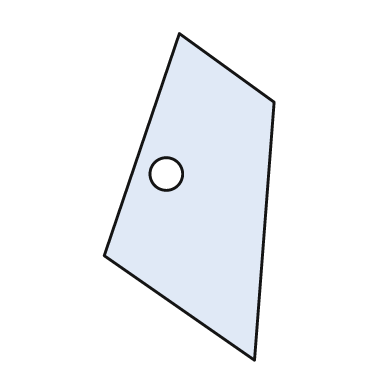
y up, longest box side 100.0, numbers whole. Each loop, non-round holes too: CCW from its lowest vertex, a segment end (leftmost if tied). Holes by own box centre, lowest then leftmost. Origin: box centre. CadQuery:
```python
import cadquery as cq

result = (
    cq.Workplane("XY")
    .moveTo(20.0, -50.0)
    .lineTo(26.0, 29.0)
    .lineTo(-3.0, 50.0)
    .lineTo(-26.0, -18.0)
    .close()
    .moveTo(-7.0, 7.0)
    .circle(5.0)
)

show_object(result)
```